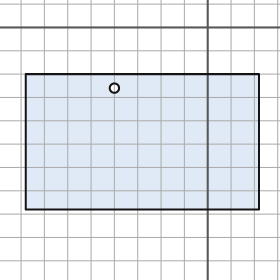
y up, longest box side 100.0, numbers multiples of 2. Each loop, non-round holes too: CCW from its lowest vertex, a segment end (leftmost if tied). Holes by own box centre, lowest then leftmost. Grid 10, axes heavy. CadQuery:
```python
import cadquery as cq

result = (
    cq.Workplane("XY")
    .moveTo(-78.0, -78.0)
    .lineTo(22.0, -78.0)
    .lineTo(22.0, -20.0)
    .lineTo(-78.0, -20.0)
    .close()
    .moveTo(-40.0, -26.0)
    .circle(2.0)
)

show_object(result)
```